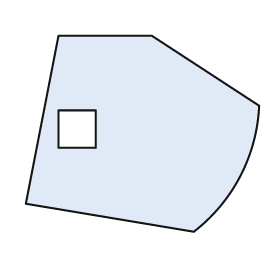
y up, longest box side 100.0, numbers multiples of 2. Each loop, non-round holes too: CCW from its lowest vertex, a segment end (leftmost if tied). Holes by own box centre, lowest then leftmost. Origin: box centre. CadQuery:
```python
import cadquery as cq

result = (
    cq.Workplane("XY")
    .moveTo(22.0, -42.0)
    .threePointArc((42.0, -18.0), (50.0, 12.0))
    .lineTo(4.0, 42.0)
    .lineTo(-36.0, 42.0)
    .lineTo(-50.0, -30.0)
    .close()
    .moveTo(-36.0, -6.0)
    .lineTo(-20.0, -6.0)
    .lineTo(-20.0, 10.0)
    .lineTo(-36.0, 10.0)
    .close()
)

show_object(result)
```